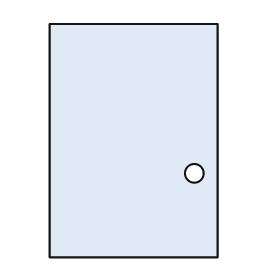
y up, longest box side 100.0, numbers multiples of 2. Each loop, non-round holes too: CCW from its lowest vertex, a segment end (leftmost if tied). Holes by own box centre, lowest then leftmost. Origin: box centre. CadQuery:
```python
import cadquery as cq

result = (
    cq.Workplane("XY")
    .moveTo(-36.0, -50.0)
    .lineTo(36.0, -50.0)
    .lineTo(36.0, 50.0)
    .lineTo(-36.0, 50.0)
    .close()
    .moveTo(26.0, -14.0)
    .circle(4.0)
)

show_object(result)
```